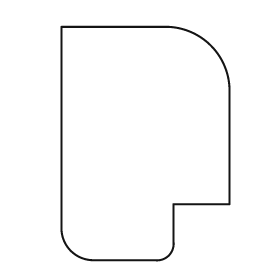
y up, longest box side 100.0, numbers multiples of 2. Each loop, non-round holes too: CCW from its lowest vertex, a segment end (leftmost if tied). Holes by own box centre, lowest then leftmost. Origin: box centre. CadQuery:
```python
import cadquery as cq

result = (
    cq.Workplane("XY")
    .moveTo(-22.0, -50.0)
    .lineTo(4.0, -50.0)
    .threePointArc((10.0, -48.0), (12.0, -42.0))
    .lineTo(12.0, -26.0)
    .lineTo(36.0, -26.0)
    .lineTo(36.0, 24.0)
    .threePointArc((28.0, 42.0), (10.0, 50.0))
    .lineTo(-36.0, 50.0)
    .lineTo(-36.0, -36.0)
    .threePointArc((-32.0, -46.0), (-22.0, -50.0))
    .close()
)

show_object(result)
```